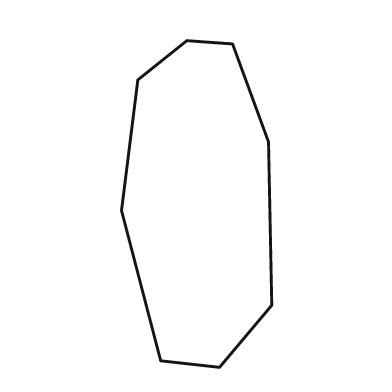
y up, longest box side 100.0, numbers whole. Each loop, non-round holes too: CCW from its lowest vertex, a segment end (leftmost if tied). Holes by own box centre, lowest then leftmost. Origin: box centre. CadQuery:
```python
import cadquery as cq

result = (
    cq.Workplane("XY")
    .moveTo(7.0, -50.0)
    .lineTo(23.0, -31.0)
    .lineTo(22.0, 19.0)
    .lineTo(11.0, 49.0)
    .lineTo(-3.0, 50.0)
    .lineTo(-18.0, 38.0)
    .lineTo(-23.0, -2.0)
    .lineTo(-11.0, -48.0)
    .close()
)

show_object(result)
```